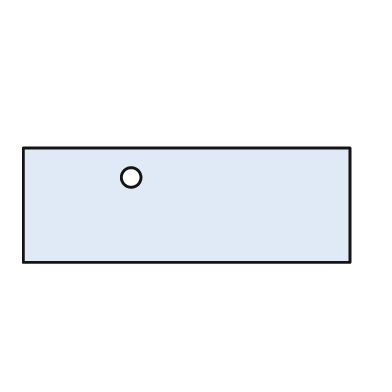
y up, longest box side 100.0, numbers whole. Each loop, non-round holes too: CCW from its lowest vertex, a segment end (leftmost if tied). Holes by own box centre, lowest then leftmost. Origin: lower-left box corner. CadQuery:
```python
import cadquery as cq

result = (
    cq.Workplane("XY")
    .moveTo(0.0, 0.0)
    .lineTo(100.0, 0.0)
    .lineTo(100.0, 35.0)
    .lineTo(0.0, 35.0)
    .close()
    .moveTo(33.0, 26.0)
    .circle(3.0)
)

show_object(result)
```